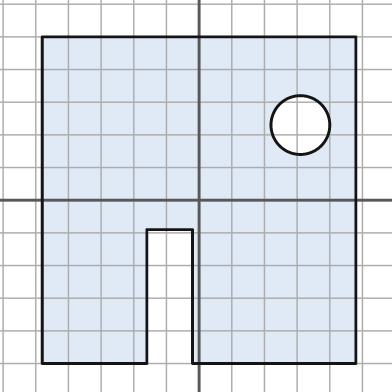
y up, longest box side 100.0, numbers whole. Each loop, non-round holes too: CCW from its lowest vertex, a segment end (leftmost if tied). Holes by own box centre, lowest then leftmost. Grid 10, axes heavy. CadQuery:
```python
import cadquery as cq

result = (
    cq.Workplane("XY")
    .moveTo(-48.0, -50.0)
    .lineTo(-16.0, -50.0)
    .lineTo(-16.0, -9.0)
    .lineTo(-2.0, -9.0)
    .lineTo(-2.0, -50.0)
    .lineTo(48.0, -50.0)
    .lineTo(48.0, 50.0)
    .lineTo(-48.0, 50.0)
    .close()
    .moveTo(31.0, 23.0)
    .circle(9.0)
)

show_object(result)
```